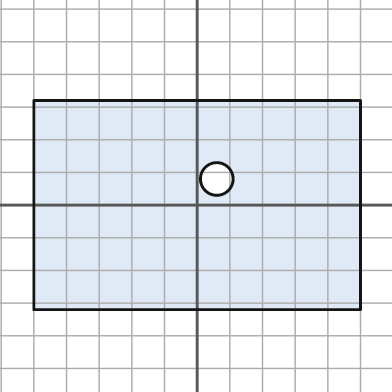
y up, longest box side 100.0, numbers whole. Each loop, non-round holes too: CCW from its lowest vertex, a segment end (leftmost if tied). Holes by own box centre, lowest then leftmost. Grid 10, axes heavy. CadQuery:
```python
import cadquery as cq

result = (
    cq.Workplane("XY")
    .moveTo(-50.0, -32.0)
    .lineTo(50.0, -32.0)
    .lineTo(50.0, 32.0)
    .lineTo(-50.0, 32.0)
    .close()
    .moveTo(6.0, 8.0)
    .circle(5.0)
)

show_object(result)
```